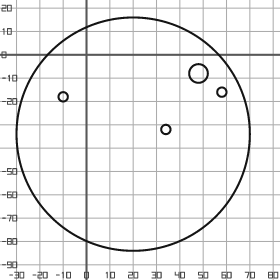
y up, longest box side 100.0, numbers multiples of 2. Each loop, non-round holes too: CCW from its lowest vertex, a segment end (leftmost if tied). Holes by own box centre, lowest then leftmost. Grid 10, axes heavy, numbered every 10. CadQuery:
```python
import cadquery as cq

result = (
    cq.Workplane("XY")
    .moveTo(20.0, -34.0)
    .circle(50.0)
    .moveTo(34.0, -32.0)
    .circle(2.0)
    .moveTo(-10.0, -18.0)
    .circle(2.0)
    .moveTo(58.0, -16.0)
    .circle(2.0)
    .moveTo(48.0, -8.0)
    .circle(4.0)
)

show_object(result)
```